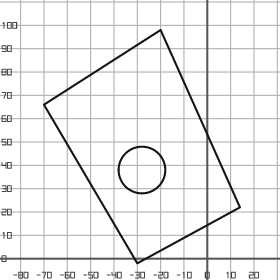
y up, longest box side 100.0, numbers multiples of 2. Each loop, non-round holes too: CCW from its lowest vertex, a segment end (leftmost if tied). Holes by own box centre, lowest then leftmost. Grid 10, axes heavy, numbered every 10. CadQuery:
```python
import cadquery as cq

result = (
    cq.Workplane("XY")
    .moveTo(-30.0, -2.0)
    .lineTo(14.0, 22.0)
    .lineTo(-20.0, 98.0)
    .lineTo(-70.0, 66.0)
    .close()
    .moveTo(-28.0, 38.0)
    .circle(10.0)
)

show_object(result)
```